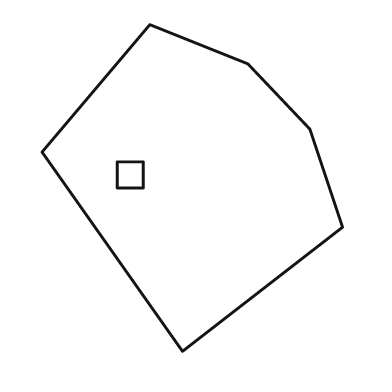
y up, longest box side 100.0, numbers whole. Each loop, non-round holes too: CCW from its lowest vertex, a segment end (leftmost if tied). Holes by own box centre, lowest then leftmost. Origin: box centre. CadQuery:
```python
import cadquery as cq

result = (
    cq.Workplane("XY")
    .moveTo(-3.0, -50.0)
    .lineTo(46.0, -12.0)
    .lineTo(36.0, 18.0)
    .lineTo(17.0, 38.0)
    .lineTo(-13.0, 50.0)
    .lineTo(-46.0, 11.0)
    .close()
    .moveTo(-23.0, 0.0)
    .lineTo(-15.0, 0.0)
    .lineTo(-15.0, 8.0)
    .lineTo(-23.0, 8.0)
    .close()
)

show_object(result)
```